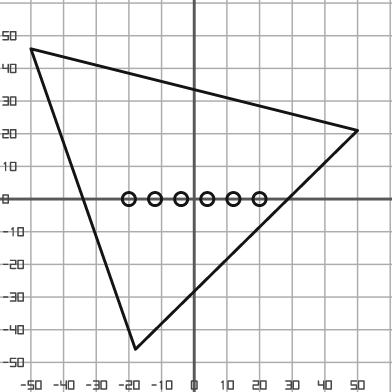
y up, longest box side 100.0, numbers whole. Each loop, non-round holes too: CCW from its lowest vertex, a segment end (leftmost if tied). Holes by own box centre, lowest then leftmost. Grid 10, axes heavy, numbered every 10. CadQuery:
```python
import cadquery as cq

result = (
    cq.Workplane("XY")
    .moveTo(-18.0, -46.0)
    .lineTo(50.0, 21.0)
    .lineTo(-50.0, 46.0)
    .close()
    .moveTo(-20.0, 0.0)
    .circle(2.0)
    .moveTo(-12.0, 0.0)
    .circle(2.0)
    .moveTo(-4.0, 0.0)
    .circle(2.0)
    .moveTo(4.0, 0.0)
    .circle(2.0)
    .moveTo(12.0, 0.0)
    .circle(2.0)
    .moveTo(20.0, 0.0)
    .circle(2.0)
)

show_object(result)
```